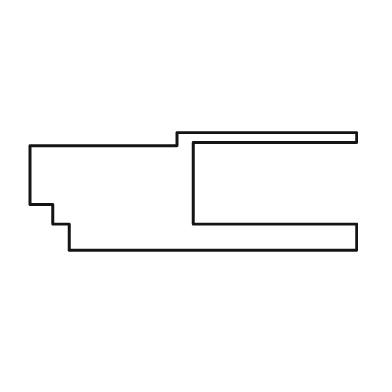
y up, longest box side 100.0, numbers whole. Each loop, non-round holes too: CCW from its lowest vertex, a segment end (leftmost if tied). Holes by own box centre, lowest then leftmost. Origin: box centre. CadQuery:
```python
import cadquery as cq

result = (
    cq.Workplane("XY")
    .moveTo(-38.0, -18.0)
    .lineTo(50.0, -18.0)
    .lineTo(50.0, -10.0)
    .lineTo(0.0, -10.0)
    .lineTo(0.0, 15.0)
    .lineTo(50.0, 15.0)
    .lineTo(50.0, 18.0)
    .lineTo(-5.0, 18.0)
    .lineTo(-5.0, 14.0)
    .lineTo(-50.0, 14.0)
    .lineTo(-50.0, -4.0)
    .lineTo(-43.0, -4.0)
    .lineTo(-43.0, -10.0)
    .lineTo(-38.0, -10.0)
    .close()
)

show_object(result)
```